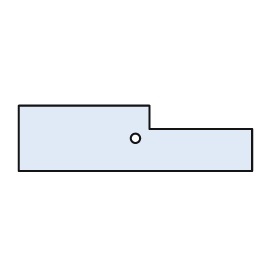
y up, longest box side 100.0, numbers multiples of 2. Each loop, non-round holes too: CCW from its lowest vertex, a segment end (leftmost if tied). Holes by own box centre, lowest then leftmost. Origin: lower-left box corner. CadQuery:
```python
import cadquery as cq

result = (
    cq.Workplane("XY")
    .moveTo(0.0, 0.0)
    .lineTo(100.0, 0.0)
    .lineTo(100.0, 18.0)
    .lineTo(56.0, 18.0)
    .lineTo(56.0, 28.0)
    .lineTo(0.0, 28.0)
    .close()
    .moveTo(50.0, 14.0)
    .circle(2.0)
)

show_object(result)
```